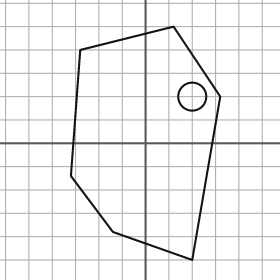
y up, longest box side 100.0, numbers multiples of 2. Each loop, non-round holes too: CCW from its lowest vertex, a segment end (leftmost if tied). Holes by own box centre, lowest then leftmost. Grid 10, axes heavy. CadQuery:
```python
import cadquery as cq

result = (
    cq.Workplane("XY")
    .moveTo(20.0, -50.0)
    .lineTo(32.0, 20.0)
    .lineTo(12.0, 50.0)
    .lineTo(-28.0, 40.0)
    .lineTo(-32.0, -14.0)
    .lineTo(-14.0, -38.0)
    .close()
    .moveTo(20.0, 20.0)
    .circle(6.0)
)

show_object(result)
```